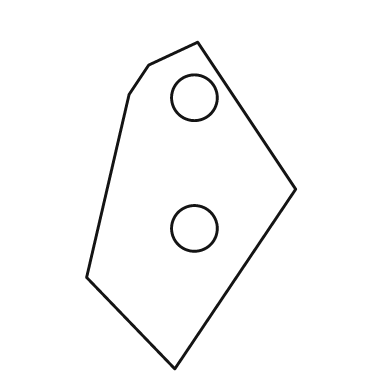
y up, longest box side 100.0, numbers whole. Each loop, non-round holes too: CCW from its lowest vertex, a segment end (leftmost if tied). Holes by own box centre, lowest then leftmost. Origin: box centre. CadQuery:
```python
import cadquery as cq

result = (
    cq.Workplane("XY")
    .moveTo(-5.0, -50.0)
    .lineTo(32.0, 5.0)
    .lineTo(2.0, 50.0)
    .lineTo(-13.0, 43.0)
    .lineTo(-19.0, 34.0)
    .lineTo(-32.0, -22.0)
    .close()
    .moveTo(1.0, -7.0)
    .circle(7.0)
    .moveTo(1.0, 33.0)
    .circle(7.0)
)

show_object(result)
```